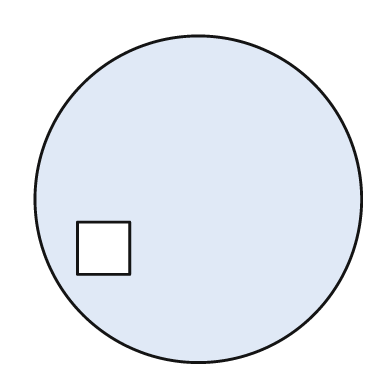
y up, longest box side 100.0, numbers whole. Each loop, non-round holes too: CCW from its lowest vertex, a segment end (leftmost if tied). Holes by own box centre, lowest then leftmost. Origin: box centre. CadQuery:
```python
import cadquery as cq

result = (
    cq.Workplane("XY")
    .moveTo(0.0, 0.0)
    .circle(50.0)
    .moveTo(-37.0, -23.0)
    .lineTo(-21.0, -23.0)
    .lineTo(-21.0, -7.0)
    .lineTo(-37.0, -7.0)
    .close()
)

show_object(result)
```